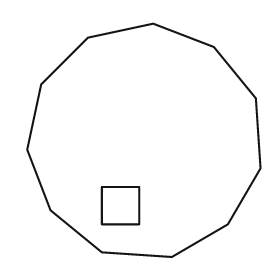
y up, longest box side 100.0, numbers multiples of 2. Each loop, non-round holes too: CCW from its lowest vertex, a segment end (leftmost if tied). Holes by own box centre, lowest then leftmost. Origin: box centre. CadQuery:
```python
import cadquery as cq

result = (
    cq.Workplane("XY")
    .moveTo(12.0, -50.0)
    .lineTo(36.0, -36.0)
    .lineTo(50.0, -12.0)
    .lineTo(48.0, 18.0)
    .lineTo(30.0, 40.0)
    .lineTo(4.0, 50.0)
    .lineTo(-24.0, 44.0)
    .lineTo(-44.0, 24.0)
    .lineTo(-50.0, -4.0)
    .lineTo(-40.0, -30.0)
    .lineTo(-18.0, -48.0)
    .close()
    .moveTo(-18.0, -36.0)
    .lineTo(-2.0, -36.0)
    .lineTo(-2.0, -20.0)
    .lineTo(-18.0, -20.0)
    .close()
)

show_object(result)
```